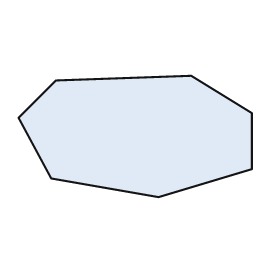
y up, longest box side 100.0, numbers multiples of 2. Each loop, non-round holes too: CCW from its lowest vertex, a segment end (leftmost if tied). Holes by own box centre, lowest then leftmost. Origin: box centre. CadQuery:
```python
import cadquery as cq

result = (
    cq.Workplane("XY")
    .moveTo(10.0, -26.0)
    .lineTo(50.0, -14.0)
    .lineTo(50.0, 10.0)
    .lineTo(24.0, 26.0)
    .lineTo(-34.0, 24.0)
    .lineTo(-50.0, 8.0)
    .lineTo(-36.0, -18.0)
    .close()
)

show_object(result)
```